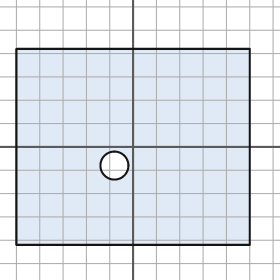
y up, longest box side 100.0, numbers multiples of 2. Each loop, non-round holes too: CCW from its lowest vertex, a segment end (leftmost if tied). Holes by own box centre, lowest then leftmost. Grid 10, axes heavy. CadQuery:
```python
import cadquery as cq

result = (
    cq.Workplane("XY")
    .moveTo(-50.0, -42.0)
    .lineTo(50.0, -42.0)
    .lineTo(50.0, 42.0)
    .lineTo(-50.0, 42.0)
    .close()
    .moveTo(-8.0, -8.0)
    .circle(6.0)
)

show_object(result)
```